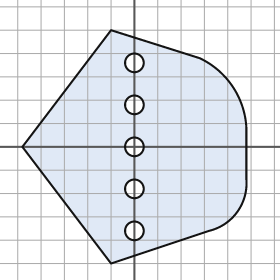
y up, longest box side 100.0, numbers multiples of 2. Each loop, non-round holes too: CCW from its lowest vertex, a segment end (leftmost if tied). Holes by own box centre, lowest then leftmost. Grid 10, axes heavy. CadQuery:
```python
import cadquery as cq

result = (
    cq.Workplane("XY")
    .moveTo(-10.0, -50.0)
    .lineTo(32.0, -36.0)
    .threePointArc((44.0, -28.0), (48.0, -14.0))
    .lineTo(48.0, 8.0)
    .threePointArc((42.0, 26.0), (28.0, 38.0))
    .lineTo(-10.0, 50.0)
    .lineTo(-48.0, 0.0)
    .close()
    .moveTo(0.0, -36.0)
    .circle(4.0)
    .moveTo(0.0, -18.0)
    .circle(4.0)
    .moveTo(0.0, 0.0)
    .circle(4.0)
    .moveTo(0.0, 18.0)
    .circle(4.0)
    .moveTo(0.0, 36.0)
    .circle(4.0)
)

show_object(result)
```